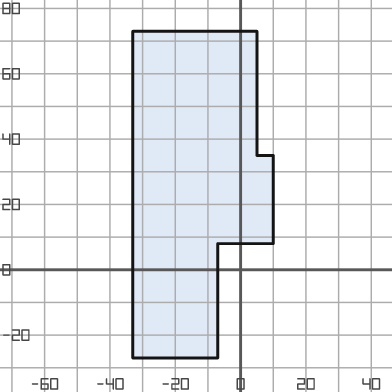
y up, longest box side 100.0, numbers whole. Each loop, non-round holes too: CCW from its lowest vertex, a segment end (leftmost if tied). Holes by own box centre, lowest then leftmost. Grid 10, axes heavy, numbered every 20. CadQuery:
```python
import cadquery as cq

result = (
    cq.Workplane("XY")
    .moveTo(-33.0, -27.0)
    .lineTo(-7.0, -27.0)
    .lineTo(-7.0, 8.0)
    .lineTo(10.0, 8.0)
    .lineTo(10.0, 35.0)
    .lineTo(5.0, 35.0)
    .lineTo(5.0, 73.0)
    .lineTo(-33.0, 73.0)
    .close()
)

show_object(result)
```